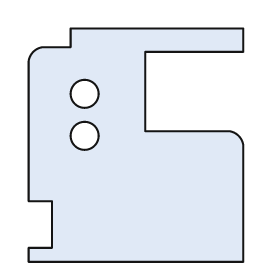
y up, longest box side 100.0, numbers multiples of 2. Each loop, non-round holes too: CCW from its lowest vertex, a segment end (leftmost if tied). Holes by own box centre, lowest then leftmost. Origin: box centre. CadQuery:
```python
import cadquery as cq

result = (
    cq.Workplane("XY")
    .moveTo(-46.0, -50.0)
    .lineTo(46.0, -50.0)
    .lineTo(46.0, 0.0)
    .threePointArc((44.0, 4.0), (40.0, 6.0))
    .lineTo(4.0, 6.0)
    .lineTo(4.0, 40.0)
    .lineTo(46.0, 40.0)
    .lineTo(46.0, 50.0)
    .lineTo(-28.0, 50.0)
    .lineTo(-28.0, 42.0)
    .lineTo(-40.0, 42.0)
    .threePointArc((-44.0, 40.0), (-46.0, 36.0))
    .lineTo(-46.0, -24.0)
    .lineTo(-36.0, -24.0)
    .lineTo(-36.0, -44.0)
    .lineTo(-46.0, -44.0)
    .close()
    .moveTo(-22.0, 4.0)
    .circle(6.0)
    .moveTo(-22.0, 22.0)
    .circle(6.0)
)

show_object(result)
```